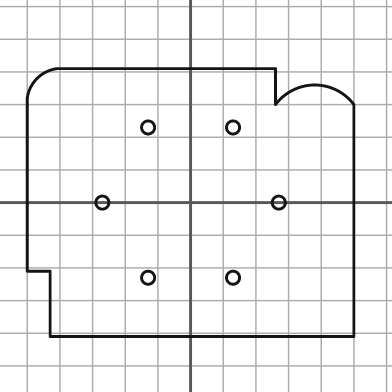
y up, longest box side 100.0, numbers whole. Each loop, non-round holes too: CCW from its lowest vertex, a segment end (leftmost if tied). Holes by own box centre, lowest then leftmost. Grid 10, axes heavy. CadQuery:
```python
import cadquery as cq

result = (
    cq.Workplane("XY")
    .moveTo(-43.0, -41.0)
    .lineTo(50.0, -41.0)
    .lineTo(50.0, 30.0)
    .threePointArc((38.0, 36.0), (26.0, 30.0))
    .lineTo(26.0, 41.0)
    .lineTo(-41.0, 41.0)
    .threePointArc((-47.0, 38.0), (-50.0, 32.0))
    .lineTo(-50.0, -21.0)
    .lineTo(-43.0, -21.0)
    .close()
    .moveTo(-13.0, -23.0)
    .circle(2.0)
    .moveTo(13.0, -23.0)
    .circle(2.0)
    .moveTo(-27.0, 0.0)
    .circle(2.0)
    .moveTo(27.0, 0.0)
    .circle(2.0)
    .moveTo(-13.0, 23.0)
    .circle(2.0)
    .moveTo(13.0, 23.0)
    .circle(2.0)
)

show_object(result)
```